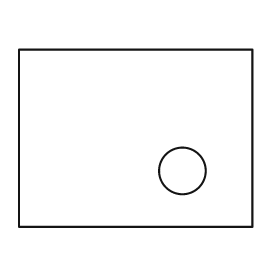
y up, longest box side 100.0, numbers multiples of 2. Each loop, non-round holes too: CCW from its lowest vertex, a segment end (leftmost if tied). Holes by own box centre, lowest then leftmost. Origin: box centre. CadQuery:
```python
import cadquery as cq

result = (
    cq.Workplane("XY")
    .moveTo(-50.0, -38.0)
    .lineTo(50.0, -38.0)
    .lineTo(50.0, 38.0)
    .lineTo(-50.0, 38.0)
    .close()
    .moveTo(20.0, -14.0)
    .circle(10.0)
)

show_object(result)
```